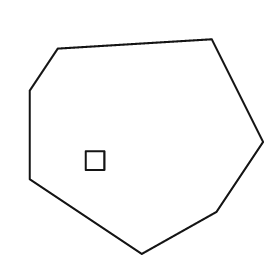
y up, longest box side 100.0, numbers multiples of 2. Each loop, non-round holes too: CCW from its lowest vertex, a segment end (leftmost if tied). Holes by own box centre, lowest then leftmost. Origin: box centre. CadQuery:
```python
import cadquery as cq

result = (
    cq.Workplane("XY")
    .moveTo(-2.0, -46.0)
    .lineTo(30.0, -28.0)
    .lineTo(50.0, 2.0)
    .lineTo(28.0, 46.0)
    .lineTo(-38.0, 42.0)
    .lineTo(-50.0, 24.0)
    .lineTo(-50.0, -14.0)
    .close()
    .moveTo(-26.0, -10.0)
    .lineTo(-18.0, -10.0)
    .lineTo(-18.0, -2.0)
    .lineTo(-26.0, -2.0)
    .close()
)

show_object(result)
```